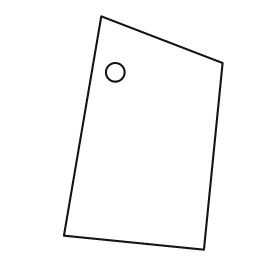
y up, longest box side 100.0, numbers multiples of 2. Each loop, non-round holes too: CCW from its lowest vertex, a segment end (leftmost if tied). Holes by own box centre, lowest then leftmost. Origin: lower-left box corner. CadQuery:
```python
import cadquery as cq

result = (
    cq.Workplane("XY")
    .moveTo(60.0, 0.0)
    .lineTo(68.0, 80.0)
    .lineTo(16.0, 100.0)
    .lineTo(0.0, 6.0)
    .close()
    .moveTo(22.0, 76.0)
    .circle(4.0)
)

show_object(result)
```